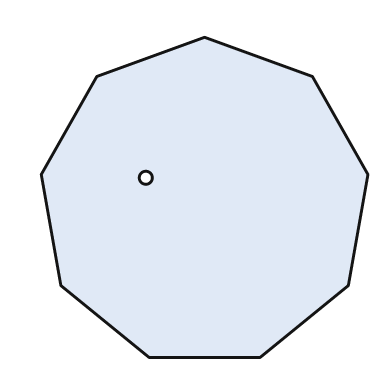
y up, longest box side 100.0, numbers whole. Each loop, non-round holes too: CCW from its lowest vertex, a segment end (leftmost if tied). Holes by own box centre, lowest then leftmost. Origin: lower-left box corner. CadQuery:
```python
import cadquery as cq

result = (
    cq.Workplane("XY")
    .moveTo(33.0, 0.0)
    .lineTo(67.0, 0.0)
    .lineTo(94.0, 22.0)
    .lineTo(100.0, 56.0)
    .lineTo(83.0, 86.0)
    .lineTo(50.0, 98.0)
    .lineTo(17.0, 86.0)
    .lineTo(0.0, 56.0)
    .lineTo(6.0, 22.0)
    .close()
    .moveTo(32.0, 55.0)
    .circle(2.0)
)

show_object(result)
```